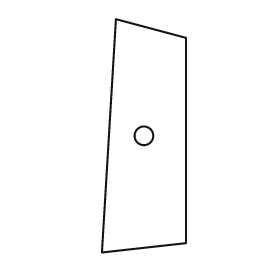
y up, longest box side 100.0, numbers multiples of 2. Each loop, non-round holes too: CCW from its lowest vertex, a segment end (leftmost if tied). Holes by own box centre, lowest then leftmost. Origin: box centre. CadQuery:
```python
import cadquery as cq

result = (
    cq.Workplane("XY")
    .moveTo(-18.0, -50.0)
    .lineTo(18.0, -46.0)
    .lineTo(18.0, 42.0)
    .lineTo(-12.0, 50.0)
    .close()
    .moveTo(0.0, 0.0)
    .circle(4.0)
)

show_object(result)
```